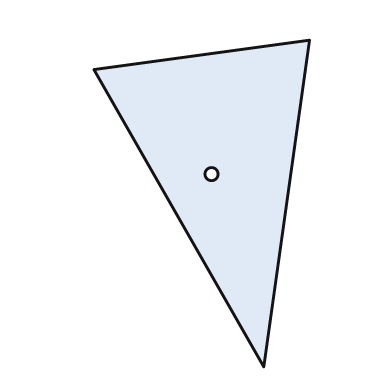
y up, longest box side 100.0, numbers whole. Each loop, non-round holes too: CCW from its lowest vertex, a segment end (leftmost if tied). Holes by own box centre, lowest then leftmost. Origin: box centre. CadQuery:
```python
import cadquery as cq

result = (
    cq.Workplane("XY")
    .moveTo(19.0, -50.0)
    .lineTo(33.0, 50.0)
    .lineTo(-33.0, 41.0)
    .close()
    .moveTo(3.0, 9.0)
    .circle(2.0)
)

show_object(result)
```